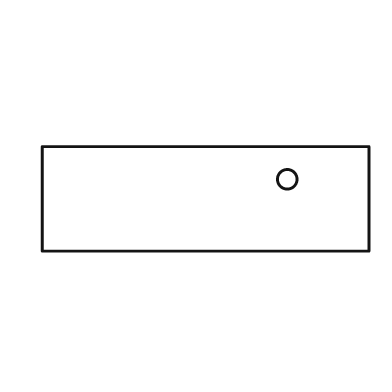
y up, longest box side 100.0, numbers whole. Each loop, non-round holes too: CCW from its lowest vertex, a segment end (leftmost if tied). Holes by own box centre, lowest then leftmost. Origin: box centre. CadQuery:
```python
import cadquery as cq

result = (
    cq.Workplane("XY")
    .moveTo(-50.0, -16.0)
    .lineTo(50.0, -16.0)
    .lineTo(50.0, 16.0)
    .lineTo(-50.0, 16.0)
    .close()
    .moveTo(25.0, 6.0)
    .circle(3.0)
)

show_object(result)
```